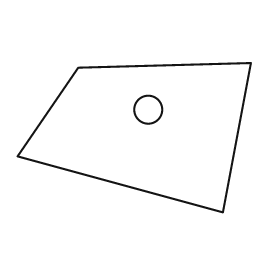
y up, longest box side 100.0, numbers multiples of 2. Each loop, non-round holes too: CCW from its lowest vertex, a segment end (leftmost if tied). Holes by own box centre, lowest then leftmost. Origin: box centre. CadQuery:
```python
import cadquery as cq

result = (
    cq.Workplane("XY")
    .moveTo(38.0, -32.0)
    .lineTo(50.0, 32.0)
    .lineTo(-24.0, 30.0)
    .lineTo(-50.0, -8.0)
    .close()
    .moveTo(6.0, 12.0)
    .circle(6.0)
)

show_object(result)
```